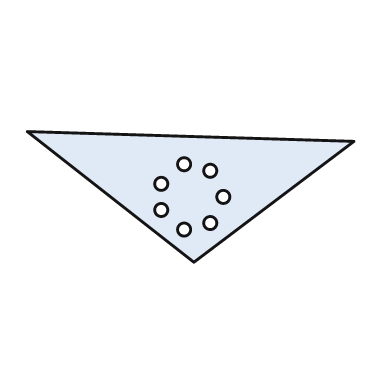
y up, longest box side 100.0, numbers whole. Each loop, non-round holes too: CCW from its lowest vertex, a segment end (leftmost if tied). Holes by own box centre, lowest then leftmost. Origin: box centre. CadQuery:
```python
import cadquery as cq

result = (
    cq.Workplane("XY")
    .moveTo(1.0, -20.0)
    .lineTo(50.0, 17.0)
    .lineTo(-50.0, 20.0)
    .close()
    .moveTo(-2.0, -10.0)
    .circle(2.0)
    .moveTo(6.0, -8.0)
    .circle(2.0)
    .moveTo(-9.0, -4.0)
    .circle(2.0)
    .moveTo(10.0, 0.0)
    .circle(2.0)
    .moveTo(-9.0, 4.0)
    .circle(2.0)
    .moveTo(6.0, 8.0)
    .circle(2.0)
    .moveTo(-2.0, 10.0)
    .circle(2.0)
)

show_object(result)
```